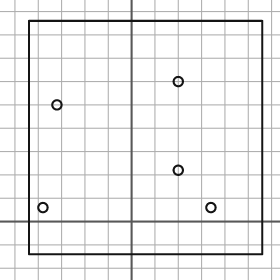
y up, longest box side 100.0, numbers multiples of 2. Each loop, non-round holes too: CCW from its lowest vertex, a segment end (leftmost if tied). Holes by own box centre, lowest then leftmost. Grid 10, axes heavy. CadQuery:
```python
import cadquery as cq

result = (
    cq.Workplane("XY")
    .moveTo(-44.0, -14.0)
    .lineTo(56.0, -14.0)
    .lineTo(56.0, 86.0)
    .lineTo(-44.0, 86.0)
    .close()
    .moveTo(-38.0, 6.0)
    .circle(2.0)
    .moveTo(34.0, 6.0)
    .circle(2.0)
    .moveTo(20.0, 22.0)
    .circle(2.0)
    .moveTo(-32.0, 50.0)
    .circle(2.0)
    .moveTo(20.0, 60.0)
    .circle(2.0)
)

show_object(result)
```